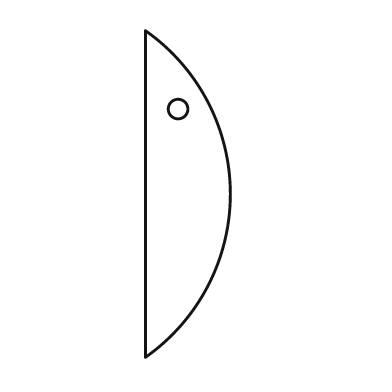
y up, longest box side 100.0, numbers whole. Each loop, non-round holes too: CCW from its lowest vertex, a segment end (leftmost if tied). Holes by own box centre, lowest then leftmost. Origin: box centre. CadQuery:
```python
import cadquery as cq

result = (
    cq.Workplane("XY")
    .moveTo(-13.0, -50.0)
    .threePointArc((13.0, 0.0), (-13.0, 50.0))
    .close()
    .moveTo(-3.0, 26.0)
    .circle(3.0)
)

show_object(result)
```